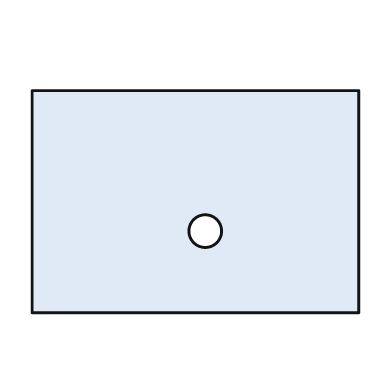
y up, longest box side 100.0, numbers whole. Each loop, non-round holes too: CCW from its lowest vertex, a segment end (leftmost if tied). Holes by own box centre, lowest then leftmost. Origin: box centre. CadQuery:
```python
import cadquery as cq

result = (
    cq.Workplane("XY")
    .moveTo(-50.0, -34.0)
    .lineTo(50.0, -34.0)
    .lineTo(50.0, 34.0)
    .lineTo(-50.0, 34.0)
    .close()
    .moveTo(3.0, -9.0)
    .circle(5.0)
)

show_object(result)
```